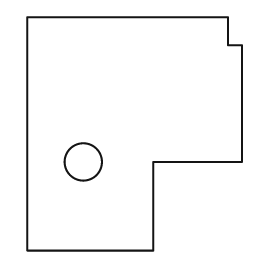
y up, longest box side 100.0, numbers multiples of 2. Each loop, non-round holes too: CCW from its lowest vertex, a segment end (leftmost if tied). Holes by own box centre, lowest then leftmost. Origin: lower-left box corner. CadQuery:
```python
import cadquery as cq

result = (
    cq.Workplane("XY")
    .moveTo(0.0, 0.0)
    .lineTo(54.0, 0.0)
    .lineTo(54.0, 38.0)
    .lineTo(92.0, 38.0)
    .lineTo(92.0, 88.0)
    .lineTo(86.0, 88.0)
    .lineTo(86.0, 100.0)
    .lineTo(0.0, 100.0)
    .close()
    .moveTo(24.0, 38.0)
    .circle(8.0)
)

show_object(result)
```